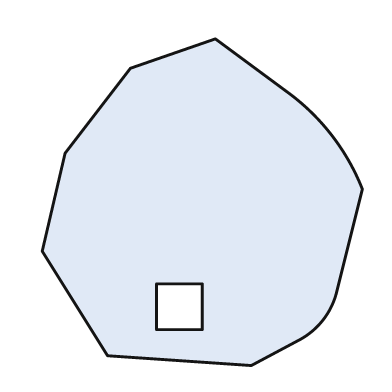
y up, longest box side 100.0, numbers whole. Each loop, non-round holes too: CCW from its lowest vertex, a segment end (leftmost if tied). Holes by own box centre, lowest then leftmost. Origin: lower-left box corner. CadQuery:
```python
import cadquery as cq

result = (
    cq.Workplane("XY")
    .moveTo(64.0, 0.0)
    .lineTo(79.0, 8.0)
    .threePointArc((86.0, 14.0), (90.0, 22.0))
    .lineTo(98.0, 54.0)
    .threePointArc((89.0, 70.0), (76.0, 83.0))
    .lineTo(53.0, 100.0)
    .lineTo(27.0, 91.0)
    .lineTo(7.0, 65.0)
    .lineTo(0.0, 35.0)
    .lineTo(20.0, 3.0)
    .close()
    .moveTo(35.0, 11.0)
    .lineTo(49.0, 11.0)
    .lineTo(49.0, 25.0)
    .lineTo(35.0, 25.0)
    .close()
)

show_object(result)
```